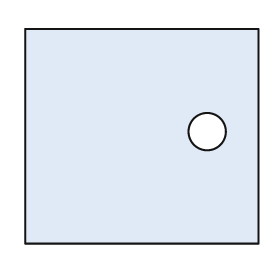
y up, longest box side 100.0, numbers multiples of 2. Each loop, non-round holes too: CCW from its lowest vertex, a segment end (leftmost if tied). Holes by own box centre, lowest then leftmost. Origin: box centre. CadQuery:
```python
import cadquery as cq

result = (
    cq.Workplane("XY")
    .moveTo(-50.0, -46.0)
    .lineTo(50.0, -46.0)
    .lineTo(50.0, 46.0)
    .lineTo(-50.0, 46.0)
    .close()
    .moveTo(28.0, 2.0)
    .circle(8.0)
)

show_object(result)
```